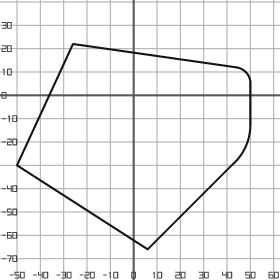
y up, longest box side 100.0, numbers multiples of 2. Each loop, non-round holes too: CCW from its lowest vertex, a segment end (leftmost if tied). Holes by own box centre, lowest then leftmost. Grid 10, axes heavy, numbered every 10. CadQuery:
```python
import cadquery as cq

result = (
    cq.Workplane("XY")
    .moveTo(6.0, -66.0)
    .lineTo(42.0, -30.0)
    .threePointArc((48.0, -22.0), (50.0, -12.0))
    .lineTo(50.0, 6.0)
    .threePointArc((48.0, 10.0), (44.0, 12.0))
    .lineTo(-26.0, 22.0)
    .lineTo(-50.0, -30.0)
    .close()
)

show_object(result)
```